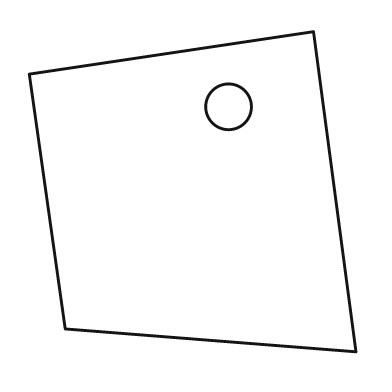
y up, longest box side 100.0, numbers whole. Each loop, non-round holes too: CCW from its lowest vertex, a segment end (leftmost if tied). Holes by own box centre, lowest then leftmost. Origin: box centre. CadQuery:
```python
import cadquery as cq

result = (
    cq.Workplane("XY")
    .moveTo(50.0, -49.0)
    .lineTo(37.0, 49.0)
    .lineTo(-50.0, 36.0)
    .lineTo(-39.0, -42.0)
    .close()
    .moveTo(11.0, 26.0)
    .circle(7.0)
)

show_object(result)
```